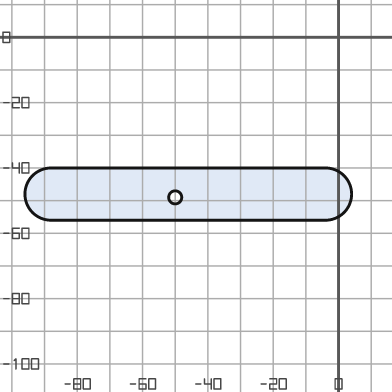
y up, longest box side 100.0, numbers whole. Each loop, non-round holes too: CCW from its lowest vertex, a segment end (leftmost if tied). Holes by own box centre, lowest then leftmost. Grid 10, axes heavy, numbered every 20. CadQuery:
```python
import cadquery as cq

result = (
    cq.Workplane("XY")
    .moveTo(-88.0, -56.0)
    .lineTo(-4.0, -56.0)
    .threePointArc((4.0, -48.0), (-4.0, -40.0))
    .lineTo(-88.0, -40.0)
    .threePointArc((-96.0, -48.0), (-88.0, -56.0))
    .close()
    .moveTo(-50.0, -49.0)
    .circle(2.0)
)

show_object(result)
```